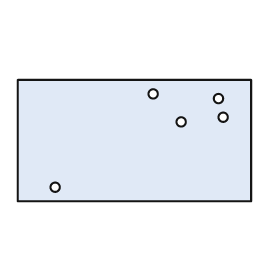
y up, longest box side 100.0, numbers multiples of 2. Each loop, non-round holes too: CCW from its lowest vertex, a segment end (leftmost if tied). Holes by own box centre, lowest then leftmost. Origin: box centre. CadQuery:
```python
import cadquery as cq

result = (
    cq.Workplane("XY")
    .moveTo(-50.0, -26.0)
    .lineTo(50.0, -26.0)
    .lineTo(50.0, 26.0)
    .lineTo(-50.0, 26.0)
    .close()
    .moveTo(-34.0, -20.0)
    .circle(2.0)
    .moveTo(20.0, 8.0)
    .circle(2.0)
    .moveTo(38.0, 10.0)
    .circle(2.0)
    .moveTo(36.0, 18.0)
    .circle(2.0)
    .moveTo(8.0, 20.0)
    .circle(2.0)
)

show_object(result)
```